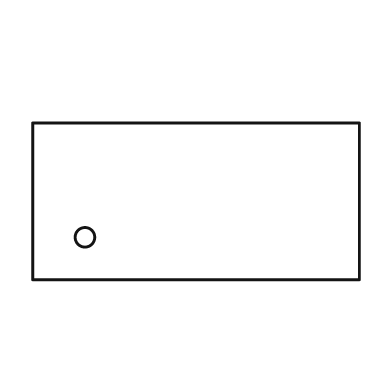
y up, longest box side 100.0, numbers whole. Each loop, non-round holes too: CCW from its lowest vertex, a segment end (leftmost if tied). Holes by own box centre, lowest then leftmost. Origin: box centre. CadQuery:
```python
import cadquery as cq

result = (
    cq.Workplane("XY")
    .moveTo(-50.0, -24.0)
    .lineTo(50.0, -24.0)
    .lineTo(50.0, 24.0)
    .lineTo(-50.0, 24.0)
    .close()
    .moveTo(-34.0, -11.0)
    .circle(3.0)
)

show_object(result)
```